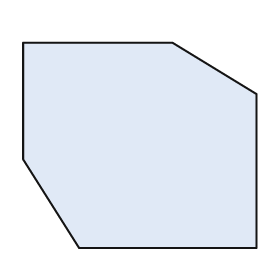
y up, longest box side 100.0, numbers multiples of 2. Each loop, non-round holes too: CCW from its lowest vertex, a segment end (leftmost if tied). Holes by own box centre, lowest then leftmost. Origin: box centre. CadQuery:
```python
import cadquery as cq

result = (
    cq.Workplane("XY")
    .moveTo(-26.0, -44.0)
    .lineTo(50.0, -44.0)
    .lineTo(50.0, 22.0)
    .lineTo(14.0, 44.0)
    .lineTo(-50.0, 44.0)
    .lineTo(-50.0, -6.0)
    .close()
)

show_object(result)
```